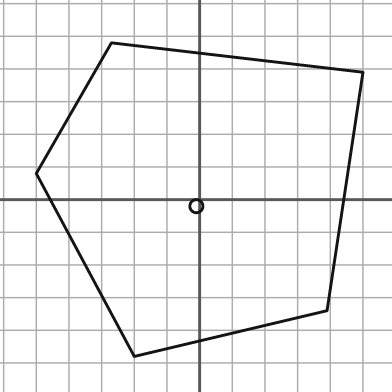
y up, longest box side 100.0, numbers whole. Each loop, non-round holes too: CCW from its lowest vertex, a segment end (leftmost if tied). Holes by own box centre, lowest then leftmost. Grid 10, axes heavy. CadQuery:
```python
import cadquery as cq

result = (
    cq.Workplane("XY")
    .moveTo(-20.0, -48.0)
    .lineTo(39.0, -34.0)
    .lineTo(50.0, 39.0)
    .lineTo(-27.0, 48.0)
    .lineTo(-50.0, 8.0)
    .close()
    .moveTo(-1.0, -2.0)
    .circle(2.0)
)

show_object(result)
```